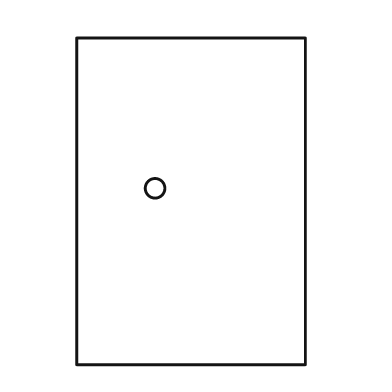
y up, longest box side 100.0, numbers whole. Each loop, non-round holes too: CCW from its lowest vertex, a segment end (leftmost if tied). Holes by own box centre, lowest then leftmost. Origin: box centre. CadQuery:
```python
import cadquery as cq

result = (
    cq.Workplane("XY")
    .moveTo(-35.0, -50.0)
    .lineTo(35.0, -50.0)
    .lineTo(35.0, 50.0)
    .lineTo(-35.0, 50.0)
    .close()
    .moveTo(-11.0, 4.0)
    .circle(3.0)
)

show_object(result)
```